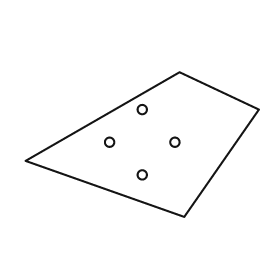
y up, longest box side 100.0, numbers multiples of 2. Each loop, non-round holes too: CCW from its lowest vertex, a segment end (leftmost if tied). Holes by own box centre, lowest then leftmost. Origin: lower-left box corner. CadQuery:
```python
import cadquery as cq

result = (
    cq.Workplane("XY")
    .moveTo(68.0, 0.0)
    .lineTo(100.0, 46.0)
    .lineTo(66.0, 62.0)
    .lineTo(0.0, 24.0)
    .close()
    .moveTo(50.0, 18.0)
    .circle(2.0)
    .moveTo(36.0, 32.0)
    .circle(2.0)
    .moveTo(64.0, 32.0)
    .circle(2.0)
    .moveTo(50.0, 46.0)
    .circle(2.0)
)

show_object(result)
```